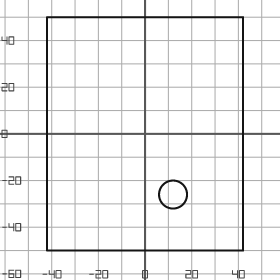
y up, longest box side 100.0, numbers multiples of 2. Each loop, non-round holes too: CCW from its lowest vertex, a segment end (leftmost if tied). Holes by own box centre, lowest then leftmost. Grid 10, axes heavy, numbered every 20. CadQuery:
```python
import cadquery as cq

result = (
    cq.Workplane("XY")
    .moveTo(-42.0, -50.0)
    .lineTo(42.0, -50.0)
    .lineTo(42.0, 50.0)
    .lineTo(-42.0, 50.0)
    .close()
    .moveTo(12.0, -26.0)
    .circle(6.0)
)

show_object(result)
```